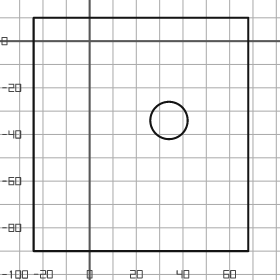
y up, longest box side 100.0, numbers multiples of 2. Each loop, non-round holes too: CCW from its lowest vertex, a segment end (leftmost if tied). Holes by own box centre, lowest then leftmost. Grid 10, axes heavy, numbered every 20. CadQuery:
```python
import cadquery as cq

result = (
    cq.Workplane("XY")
    .moveTo(-24.0, -90.0)
    .lineTo(68.0, -90.0)
    .lineTo(68.0, 10.0)
    .lineTo(-24.0, 10.0)
    .close()
    .moveTo(34.0, -34.0)
    .circle(8.0)
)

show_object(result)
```